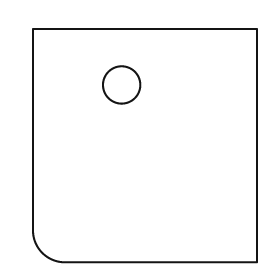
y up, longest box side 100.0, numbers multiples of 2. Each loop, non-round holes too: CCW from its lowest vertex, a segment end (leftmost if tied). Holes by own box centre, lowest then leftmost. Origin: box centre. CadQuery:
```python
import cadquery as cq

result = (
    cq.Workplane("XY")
    .moveTo(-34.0, -50.0)
    .lineTo(48.0, -50.0)
    .lineTo(48.0, 50.0)
    .lineTo(-48.0, 50.0)
    .lineTo(-48.0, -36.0)
    .threePointArc((-44.0, -46.0), (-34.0, -50.0))
    .close()
    .moveTo(-10.0, 26.0)
    .circle(8.0)
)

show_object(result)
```